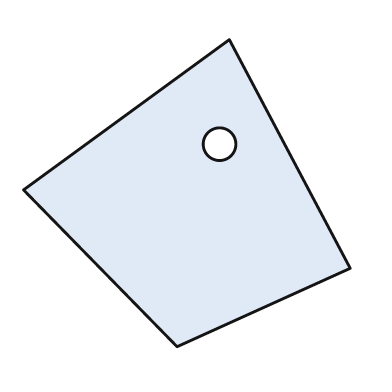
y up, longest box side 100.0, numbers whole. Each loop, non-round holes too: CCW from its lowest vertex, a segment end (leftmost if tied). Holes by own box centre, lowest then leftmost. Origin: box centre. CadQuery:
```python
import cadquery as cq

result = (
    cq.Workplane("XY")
    .moveTo(-3.0, -47.0)
    .lineTo(50.0, -23.0)
    .lineTo(13.0, 47.0)
    .lineTo(-50.0, 1.0)
    .close()
    .moveTo(10.0, 15.0)
    .circle(5.0)
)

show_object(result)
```